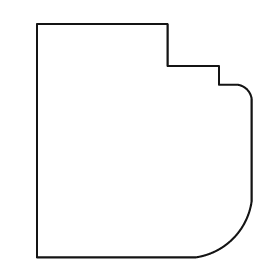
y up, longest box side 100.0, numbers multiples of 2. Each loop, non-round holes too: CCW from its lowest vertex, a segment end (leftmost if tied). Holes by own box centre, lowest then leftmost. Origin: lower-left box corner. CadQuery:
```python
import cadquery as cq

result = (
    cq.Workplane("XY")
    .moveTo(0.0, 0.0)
    .lineTo(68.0, 0.0)
    .threePointArc((84.0, 8.0), (92.0, 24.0))
    .lineTo(92.0, 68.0)
    .threePointArc((90.0, 72.0), (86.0, 74.0))
    .lineTo(78.0, 74.0)
    .lineTo(78.0, 82.0)
    .lineTo(56.0, 82.0)
    .lineTo(56.0, 100.0)
    .lineTo(0.0, 100.0)
    .close()
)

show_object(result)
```